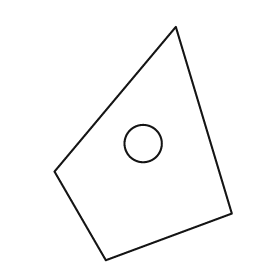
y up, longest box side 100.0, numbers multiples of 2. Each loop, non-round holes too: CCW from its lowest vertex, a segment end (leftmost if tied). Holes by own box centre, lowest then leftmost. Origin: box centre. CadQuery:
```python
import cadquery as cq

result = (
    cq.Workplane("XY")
    .moveTo(-16.0, -50.0)
    .lineTo(38.0, -30.0)
    .lineTo(14.0, 50.0)
    .lineTo(-38.0, -12.0)
    .close()
    .moveTo(0.0, 0.0)
    .circle(8.0)
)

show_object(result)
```